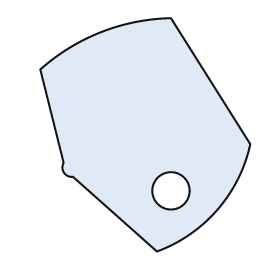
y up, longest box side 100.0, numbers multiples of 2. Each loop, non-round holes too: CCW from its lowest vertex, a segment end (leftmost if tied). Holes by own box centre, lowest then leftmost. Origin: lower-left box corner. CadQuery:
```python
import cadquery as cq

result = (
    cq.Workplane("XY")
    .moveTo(50.0, 0.0)
    .threePointArc((76.0, 18.0), (90.0, 46.0))
    .lineTo(56.0, 100.0)
    .threePointArc((26.0, 94.0), (0.0, 78.0))
    .lineTo(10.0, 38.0)
    .threePointArc((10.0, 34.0), (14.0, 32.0))
    .close()
    .moveTo(56.0, 26.0)
    .circle(8.0)
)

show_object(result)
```